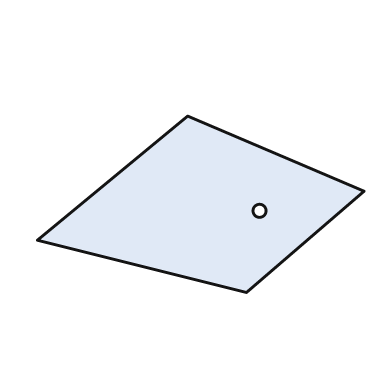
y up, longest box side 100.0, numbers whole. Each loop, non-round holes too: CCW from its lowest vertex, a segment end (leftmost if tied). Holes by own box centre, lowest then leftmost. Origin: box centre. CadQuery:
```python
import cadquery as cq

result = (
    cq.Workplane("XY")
    .moveTo(14.0, -27.0)
    .lineTo(50.0, 4.0)
    .lineTo(-4.0, 27.0)
    .lineTo(-50.0, -11.0)
    .close()
    .moveTo(18.0, -2.0)
    .circle(2.0)
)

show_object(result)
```